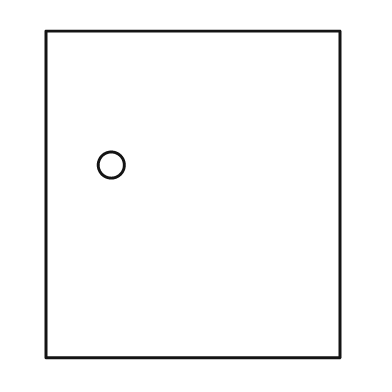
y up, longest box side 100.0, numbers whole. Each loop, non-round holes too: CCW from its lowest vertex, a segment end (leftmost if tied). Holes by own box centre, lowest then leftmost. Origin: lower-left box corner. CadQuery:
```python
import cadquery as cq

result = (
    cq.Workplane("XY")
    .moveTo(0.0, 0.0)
    .lineTo(90.0, 0.0)
    .lineTo(90.0, 100.0)
    .lineTo(0.0, 100.0)
    .close()
    .moveTo(20.0, 59.0)
    .circle(4.0)
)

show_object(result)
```